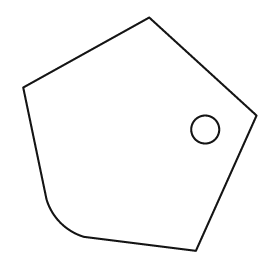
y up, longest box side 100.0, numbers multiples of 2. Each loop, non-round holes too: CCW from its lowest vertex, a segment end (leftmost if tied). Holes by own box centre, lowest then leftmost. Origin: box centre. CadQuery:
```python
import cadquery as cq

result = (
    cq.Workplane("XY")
    .moveTo(24.0, -50.0)
    .lineTo(50.0, 8.0)
    .lineTo(4.0, 50.0)
    .lineTo(-50.0, 20.0)
    .lineTo(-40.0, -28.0)
    .threePointArc((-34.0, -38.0), (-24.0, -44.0))
    .close()
    .moveTo(28.0, 2.0)
    .circle(6.0)
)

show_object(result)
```